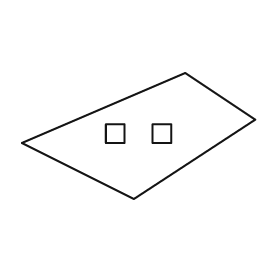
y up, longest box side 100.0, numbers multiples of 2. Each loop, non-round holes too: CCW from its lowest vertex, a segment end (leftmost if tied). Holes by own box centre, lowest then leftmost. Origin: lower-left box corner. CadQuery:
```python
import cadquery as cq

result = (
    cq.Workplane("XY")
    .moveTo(48.0, 0.0)
    .lineTo(100.0, 34.0)
    .lineTo(70.0, 54.0)
    .lineTo(0.0, 24.0)
    .close()
    .moveTo(36.0, 24.0)
    .lineTo(44.0, 24.0)
    .lineTo(44.0, 32.0)
    .lineTo(36.0, 32.0)
    .close()
    .moveTo(56.0, 24.0)
    .lineTo(64.0, 24.0)
    .lineTo(64.0, 32.0)
    .lineTo(56.0, 32.0)
    .close()
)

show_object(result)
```